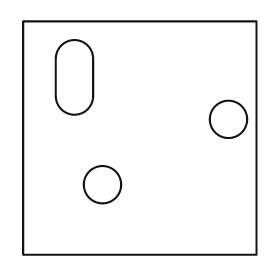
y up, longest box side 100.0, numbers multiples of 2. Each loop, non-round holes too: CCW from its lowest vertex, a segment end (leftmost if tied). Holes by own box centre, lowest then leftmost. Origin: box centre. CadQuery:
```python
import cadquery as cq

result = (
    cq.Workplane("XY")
    .moveTo(-50.0, -50.0)
    .lineTo(50.0, -50.0)
    .lineTo(50.0, 50.0)
    .lineTo(-50.0, 50.0)
    .close()
    .moveTo(-16.0, -20.0)
    .circle(8.0)
    .moveTo(38.0, 8.0)
    .circle(8.0)
    .moveTo(-36.0, 18.0)
    .threePointArc((-28.0, 10.0), (-20.0, 18.0))
    .lineTo(-20.0, 34.0)
    .threePointArc((-28.0, 42.0), (-36.0, 34.0))
    .close()
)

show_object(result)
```